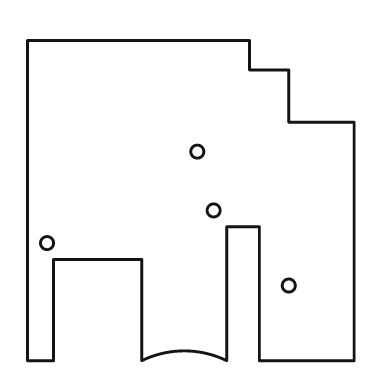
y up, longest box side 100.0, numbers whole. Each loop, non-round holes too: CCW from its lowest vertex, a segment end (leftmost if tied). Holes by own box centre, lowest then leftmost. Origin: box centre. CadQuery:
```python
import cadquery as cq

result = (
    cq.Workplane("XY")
    .moveTo(-50.0, -49.0)
    .lineTo(-42.0, -49.0)
    .lineTo(-42.0, -18.0)
    .lineTo(-15.0, -18.0)
    .lineTo(-15.0, -49.0)
    .threePointArc((-2.0, -46.0), (11.0, -49.0))
    .lineTo(11.0, -8.0)
    .lineTo(21.0, -8.0)
    .lineTo(21.0, -49.0)
    .lineTo(50.0, -49.0)
    .lineTo(50.0, 24.0)
    .lineTo(30.0, 24.0)
    .lineTo(30.0, 40.0)
    .lineTo(18.0, 40.0)
    .lineTo(18.0, 49.0)
    .lineTo(-50.0, 49.0)
    .close()
    .moveTo(30.0, -26.0)
    .circle(2.0)
    .moveTo(-44.0, -13.0)
    .circle(2.0)
    .moveTo(7.0, -3.0)
    .circle(2.0)
    .moveTo(2.0, 15.0)
    .circle(2.0)
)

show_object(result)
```